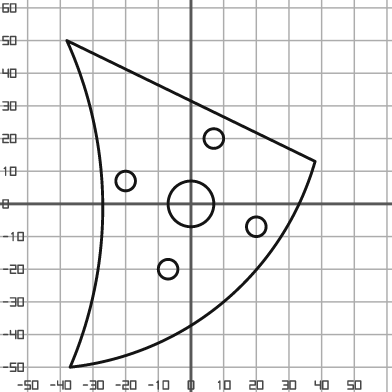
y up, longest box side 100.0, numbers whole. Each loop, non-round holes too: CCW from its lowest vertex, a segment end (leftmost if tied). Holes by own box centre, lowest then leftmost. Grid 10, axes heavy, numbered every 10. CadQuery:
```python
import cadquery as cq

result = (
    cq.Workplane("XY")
    .moveTo(-37.0, -50.0)
    .threePointArc((10.0, -30.0), (38.0, 13.0))
    .lineTo(-38.0, 50.0)
    .threePointArc((-27.0, 0.0), (-37.0, -50.0))
    .close()
    .moveTo(-7.0, -20.0)
    .circle(3.0)
    .moveTo(20.0, -7.0)
    .circle(3.0)
    .moveTo(0.0, 0.0)
    .circle(7.0)
    .moveTo(-20.0, 7.0)
    .circle(3.0)
    .moveTo(7.0, 20.0)
    .circle(3.0)
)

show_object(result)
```